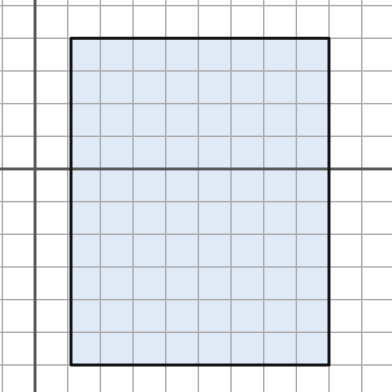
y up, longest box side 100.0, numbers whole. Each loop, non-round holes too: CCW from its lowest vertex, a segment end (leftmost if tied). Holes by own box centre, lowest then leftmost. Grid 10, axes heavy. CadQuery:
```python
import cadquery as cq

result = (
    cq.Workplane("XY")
    .moveTo(11.0, -60.0)
    .lineTo(90.0, -60.0)
    .lineTo(90.0, 40.0)
    .lineTo(11.0, 40.0)
    .close()
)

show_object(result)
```